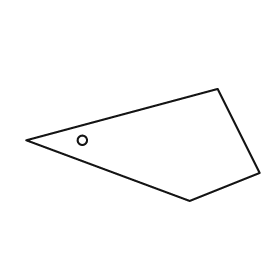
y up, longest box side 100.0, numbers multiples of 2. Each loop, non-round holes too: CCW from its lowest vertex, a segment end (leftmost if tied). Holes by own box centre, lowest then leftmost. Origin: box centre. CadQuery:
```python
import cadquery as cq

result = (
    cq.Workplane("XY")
    .moveTo(20.0, -24.0)
    .lineTo(50.0, -12.0)
    .lineTo(32.0, 24.0)
    .lineTo(-50.0, 2.0)
    .close()
    .moveTo(-26.0, 2.0)
    .circle(2.0)
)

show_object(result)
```